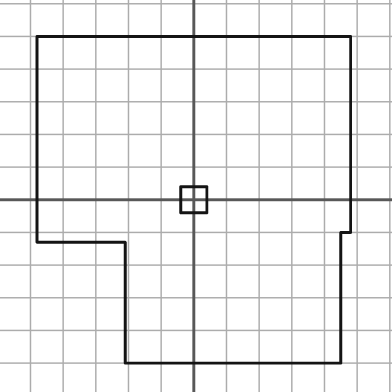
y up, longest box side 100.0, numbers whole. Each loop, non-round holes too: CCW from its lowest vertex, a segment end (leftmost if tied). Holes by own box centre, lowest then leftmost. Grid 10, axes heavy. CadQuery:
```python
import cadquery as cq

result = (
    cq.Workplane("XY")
    .moveTo(-21.0, -50.0)
    .lineTo(45.0, -50.0)
    .lineTo(45.0, -10.0)
    .lineTo(48.0, -10.0)
    .lineTo(48.0, 50.0)
    .lineTo(-48.0, 50.0)
    .lineTo(-48.0, -13.0)
    .lineTo(-21.0, -13.0)
    .close()
    .moveTo(-4.0, -4.0)
    .lineTo(4.0, -4.0)
    .lineTo(4.0, 4.0)
    .lineTo(-4.0, 4.0)
    .close()
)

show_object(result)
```